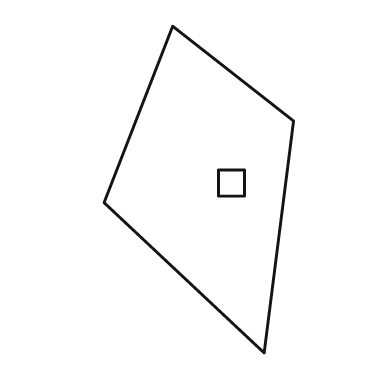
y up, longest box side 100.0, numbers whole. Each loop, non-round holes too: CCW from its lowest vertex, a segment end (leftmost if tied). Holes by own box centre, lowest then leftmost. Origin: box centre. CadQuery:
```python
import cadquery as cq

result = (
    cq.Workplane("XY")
    .moveTo(20.0, -50.0)
    .lineTo(29.0, 21.0)
    .lineTo(-8.0, 50.0)
    .lineTo(-29.0, -4.0)
    .close()
    .moveTo(6.0, -2.0)
    .lineTo(14.0, -2.0)
    .lineTo(14.0, 6.0)
    .lineTo(6.0, 6.0)
    .close()
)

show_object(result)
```